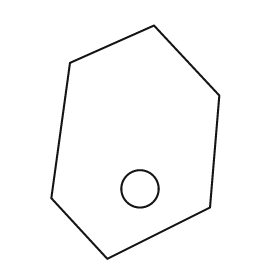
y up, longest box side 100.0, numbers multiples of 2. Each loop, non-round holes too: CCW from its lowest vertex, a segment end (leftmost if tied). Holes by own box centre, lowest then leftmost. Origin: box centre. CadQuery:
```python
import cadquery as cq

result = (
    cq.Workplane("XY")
    .moveTo(-12.0, -50.0)
    .lineTo(32.0, -28.0)
    .lineTo(36.0, 20.0)
    .lineTo(8.0, 50.0)
    .lineTo(-28.0, 34.0)
    .lineTo(-36.0, -24.0)
    .close()
    .moveTo(2.0, -20.0)
    .circle(8.0)
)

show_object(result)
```